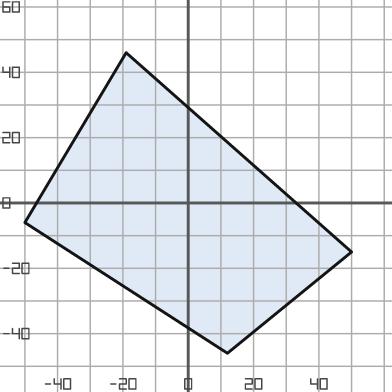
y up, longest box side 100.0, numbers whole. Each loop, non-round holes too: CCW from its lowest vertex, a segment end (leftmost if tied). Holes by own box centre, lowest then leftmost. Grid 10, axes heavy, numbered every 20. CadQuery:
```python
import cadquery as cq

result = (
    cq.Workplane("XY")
    .moveTo(12.0, -46.0)
    .lineTo(50.0, -15.0)
    .lineTo(-19.0, 46.0)
    .lineTo(-50.0, -6.0)
    .close()
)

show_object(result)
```